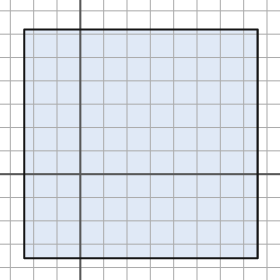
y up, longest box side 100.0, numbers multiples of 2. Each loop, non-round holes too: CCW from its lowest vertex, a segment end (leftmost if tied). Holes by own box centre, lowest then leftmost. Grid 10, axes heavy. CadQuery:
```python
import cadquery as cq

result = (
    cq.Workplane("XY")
    .moveTo(-24.0, -36.0)
    .lineTo(76.0, -36.0)
    .lineTo(76.0, 62.0)
    .lineTo(-24.0, 62.0)
    .close()
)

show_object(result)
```